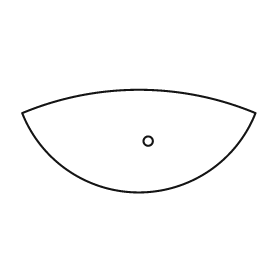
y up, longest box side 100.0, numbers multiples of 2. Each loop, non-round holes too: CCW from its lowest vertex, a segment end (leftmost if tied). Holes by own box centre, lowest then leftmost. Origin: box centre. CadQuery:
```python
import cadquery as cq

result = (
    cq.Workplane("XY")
    .moveTo(-50.0, 12.0)
    .threePointArc((0.0, -22.0), (50.0, 12.0))
    .threePointArc((0.0, 22.0), (-50.0, 12.0))
    .close()
    .moveTo(4.0, 0.0)
    .circle(2.0)
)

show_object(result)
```